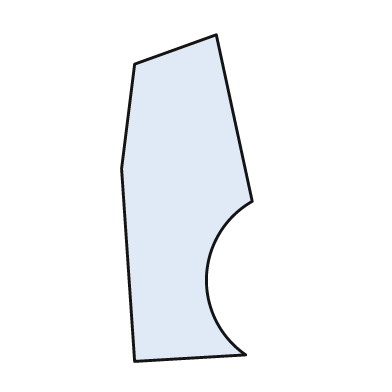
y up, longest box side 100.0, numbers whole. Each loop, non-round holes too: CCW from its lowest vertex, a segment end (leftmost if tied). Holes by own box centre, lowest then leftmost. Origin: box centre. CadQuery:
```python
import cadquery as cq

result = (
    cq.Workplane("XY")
    .moveTo(-16.0, -50.0)
    .lineTo(18.0, -48.0)
    .threePointArc((6.0, -24.0), (20.0, -1.0))
    .lineTo(9.0, 50.0)
    .lineTo(-16.0, 41.0)
    .lineTo(-20.0, 9.0)
    .close()
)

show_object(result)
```